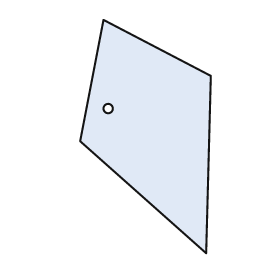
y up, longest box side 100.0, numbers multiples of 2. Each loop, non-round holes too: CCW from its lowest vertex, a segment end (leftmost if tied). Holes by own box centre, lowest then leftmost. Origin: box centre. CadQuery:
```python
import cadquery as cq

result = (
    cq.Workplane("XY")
    .moveTo(26.0, -50.0)
    .lineTo(28.0, 26.0)
    .lineTo(-18.0, 50.0)
    .lineTo(-28.0, -2.0)
    .close()
    .moveTo(-16.0, 12.0)
    .circle(2.0)
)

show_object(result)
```